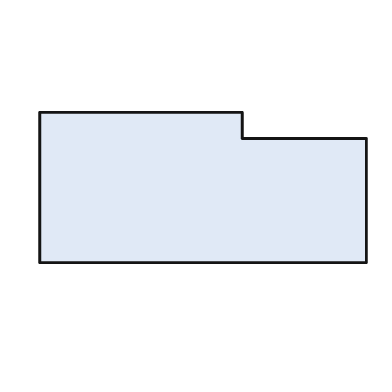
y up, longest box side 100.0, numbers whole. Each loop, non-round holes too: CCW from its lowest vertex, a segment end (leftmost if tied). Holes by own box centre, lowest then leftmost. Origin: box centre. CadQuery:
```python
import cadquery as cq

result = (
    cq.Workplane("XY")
    .moveTo(-50.0, -23.0)
    .lineTo(50.0, -23.0)
    .lineTo(50.0, 15.0)
    .lineTo(12.0, 15.0)
    .lineTo(12.0, 23.0)
    .lineTo(-50.0, 23.0)
    .close()
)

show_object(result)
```